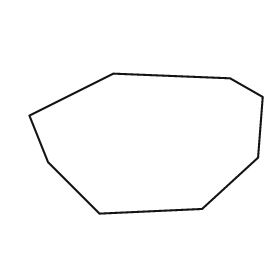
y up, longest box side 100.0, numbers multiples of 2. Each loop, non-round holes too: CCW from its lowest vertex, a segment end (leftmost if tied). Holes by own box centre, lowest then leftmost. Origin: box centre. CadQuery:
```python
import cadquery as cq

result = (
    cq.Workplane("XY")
    .moveTo(-20.0, -30.0)
    .lineTo(24.0, -28.0)
    .lineTo(48.0, -6.0)
    .lineTo(50.0, 20.0)
    .lineTo(36.0, 28.0)
    .lineTo(-14.0, 30.0)
    .lineTo(-50.0, 12.0)
    .lineTo(-42.0, -8.0)
    .close()
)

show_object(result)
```